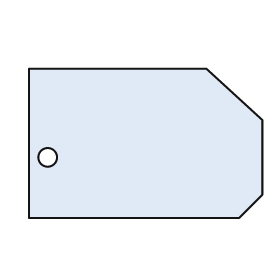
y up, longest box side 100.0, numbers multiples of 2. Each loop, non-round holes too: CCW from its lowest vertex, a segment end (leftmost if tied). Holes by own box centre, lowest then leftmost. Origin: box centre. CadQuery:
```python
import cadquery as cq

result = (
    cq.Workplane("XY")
    .moveTo(-50.0, -32.0)
    .lineTo(40.0, -32.0)
    .lineTo(50.0, -22.0)
    .lineTo(50.0, 10.0)
    .lineTo(26.0, 32.0)
    .lineTo(-50.0, 32.0)
    .close()
    .moveTo(-42.0, -6.0)
    .circle(4.0)
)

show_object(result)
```